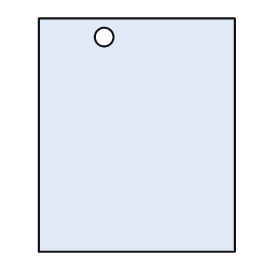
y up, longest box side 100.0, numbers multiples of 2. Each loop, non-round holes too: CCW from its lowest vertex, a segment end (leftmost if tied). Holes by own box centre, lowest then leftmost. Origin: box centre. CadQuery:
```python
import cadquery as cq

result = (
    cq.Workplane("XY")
    .moveTo(-42.0, -50.0)
    .lineTo(42.0, -50.0)
    .lineTo(42.0, 50.0)
    .lineTo(-42.0, 50.0)
    .close()
    .moveTo(-14.0, 42.0)
    .circle(4.0)
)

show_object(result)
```